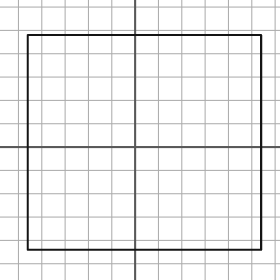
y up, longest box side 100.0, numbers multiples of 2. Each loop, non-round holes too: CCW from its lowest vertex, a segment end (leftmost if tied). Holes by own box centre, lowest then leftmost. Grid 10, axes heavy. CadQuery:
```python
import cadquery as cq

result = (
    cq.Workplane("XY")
    .moveTo(-46.0, -44.0)
    .lineTo(54.0, -44.0)
    .lineTo(54.0, 48.0)
    .lineTo(-46.0, 48.0)
    .close()
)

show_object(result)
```